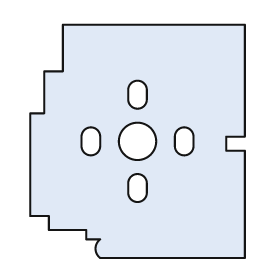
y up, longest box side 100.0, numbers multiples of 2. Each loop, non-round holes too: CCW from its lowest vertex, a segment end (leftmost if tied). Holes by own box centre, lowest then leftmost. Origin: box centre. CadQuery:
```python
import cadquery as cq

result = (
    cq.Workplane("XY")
    .moveTo(-16.0, -50.0)
    .lineTo(46.0, -50.0)
    .lineTo(46.0, -4.0)
    .lineTo(38.0, -4.0)
    .lineTo(38.0, 2.0)
    .lineTo(46.0, 2.0)
    .lineTo(46.0, 50.0)
    .lineTo(-32.0, 50.0)
    .lineTo(-32.0, 30.0)
    .lineTo(-40.0, 30.0)
    .lineTo(-40.0, 12.0)
    .lineTo(-46.0, 12.0)
    .lineTo(-46.0, -32.0)
    .lineTo(-38.0, -32.0)
    .lineTo(-38.0, -38.0)
    .lineTo(-22.0, -38.0)
    .lineTo(-22.0, -42.0)
    .lineTo(-16.0, -42.0)
    .threePointArc((-18.0, -46.0), (-16.0, -50.0))
    .close()
    .moveTo(-4.0, -22.0)
    .threePointArc((0.0, -26.0), (4.0, -22.0))
    .lineTo(4.0, -18.0)
    .threePointArc((0.0, -14.0), (-4.0, -18.0))
    .close()
    .moveTo(-24.0, -2.0)
    .threePointArc((-20.0, -6.0), (-16.0, -2.0))
    .lineTo(-16.0, 2.0)
    .threePointArc((-20.0, 6.0), (-24.0, 2.0))
    .close()
    .moveTo(0.0, 0.0)
    .circle(8.0)
    .moveTo(16.0, -2.0)
    .threePointArc((20.0, -6.0), (24.0, -2.0))
    .lineTo(24.0, 2.0)
    .threePointArc((20.0, 6.0), (16.0, 2.0))
    .close()
    .moveTo(-4.0, 18.0)
    .threePointArc((0.0, 14.0), (4.0, 18.0))
    .lineTo(4.0, 22.0)
    .threePointArc((0.0, 26.0), (-4.0, 22.0))
    .close()
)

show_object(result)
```